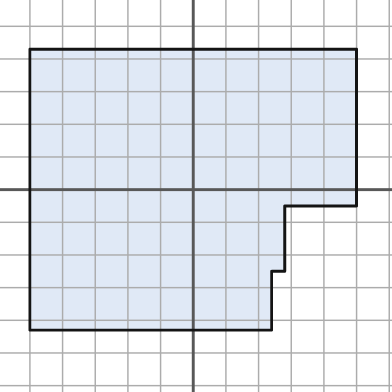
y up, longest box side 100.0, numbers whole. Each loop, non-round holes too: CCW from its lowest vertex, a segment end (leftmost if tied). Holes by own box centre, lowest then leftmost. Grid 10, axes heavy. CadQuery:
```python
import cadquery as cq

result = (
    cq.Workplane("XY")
    .moveTo(-50.0, -43.0)
    .lineTo(24.0, -43.0)
    .lineTo(24.0, -25.0)
    .lineTo(28.0, -25.0)
    .lineTo(28.0, -5.0)
    .lineTo(50.0, -5.0)
    .lineTo(50.0, 43.0)
    .lineTo(-50.0, 43.0)
    .close()
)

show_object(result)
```